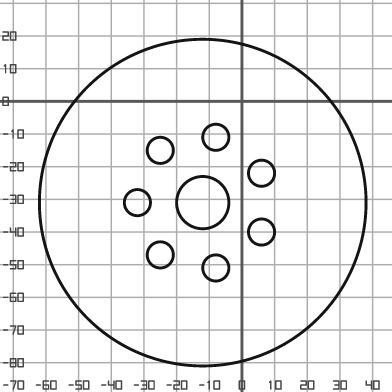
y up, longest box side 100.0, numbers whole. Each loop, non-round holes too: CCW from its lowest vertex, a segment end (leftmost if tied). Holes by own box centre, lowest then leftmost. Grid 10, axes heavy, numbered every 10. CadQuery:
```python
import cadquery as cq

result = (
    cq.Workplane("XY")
    .moveTo(-12.0, -31.0)
    .circle(50.0)
    .moveTo(-8.0, -51.0)
    .circle(4.0)
    .moveTo(-25.0, -47.0)
    .circle(4.0)
    .moveTo(6.0, -40.0)
    .circle(4.0)
    .moveTo(-32.0, -31.0)
    .circle(4.0)
    .moveTo(-12.0, -31.0)
    .circle(8.0)
    .moveTo(6.0, -22.0)
    .circle(4.0)
    .moveTo(-25.0, -15.0)
    .circle(4.0)
    .moveTo(-8.0, -11.0)
    .circle(4.0)
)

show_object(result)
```